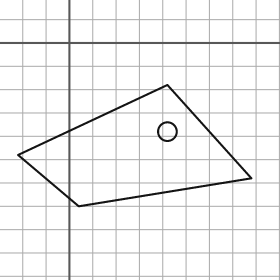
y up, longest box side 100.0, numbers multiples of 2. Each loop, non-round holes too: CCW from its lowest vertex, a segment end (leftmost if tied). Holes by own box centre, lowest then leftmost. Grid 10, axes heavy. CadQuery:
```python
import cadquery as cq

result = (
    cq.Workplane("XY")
    .moveTo(4.0, -70.0)
    .lineTo(78.0, -58.0)
    .lineTo(42.0, -18.0)
    .lineTo(-22.0, -48.0)
    .close()
    .moveTo(42.0, -38.0)
    .circle(4.0)
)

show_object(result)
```